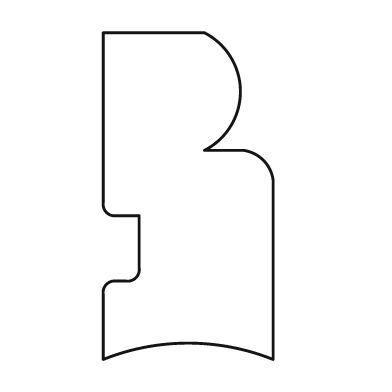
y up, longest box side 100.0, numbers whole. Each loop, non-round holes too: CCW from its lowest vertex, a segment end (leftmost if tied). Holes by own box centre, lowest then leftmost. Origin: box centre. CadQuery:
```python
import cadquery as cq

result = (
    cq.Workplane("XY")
    .moveTo(-26.0, -50.0)
    .threePointArc((0.0, -45.0), (26.0, -50.0))
    .lineTo(26.0, 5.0)
    .threePointArc((23.0, 11.0), (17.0, 14.0))
    .lineTo(5.0, 14.0)
    .threePointArc((16.0, 32.0), (5.0, 50.0))
    .lineTo(-26.0, 50.0)
    .lineTo(-26.0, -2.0)
    .threePointArc((-25.0, -5.0), (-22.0, -6.0))
    .lineTo(-15.0, -6.0)
    .lineTo(-15.0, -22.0)
    .threePointArc((-16.0, -25.0), (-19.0, -26.0))
    .lineTo(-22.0, -26.0)
    .threePointArc((-25.0, -27.0), (-26.0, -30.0))
    .close()
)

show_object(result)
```